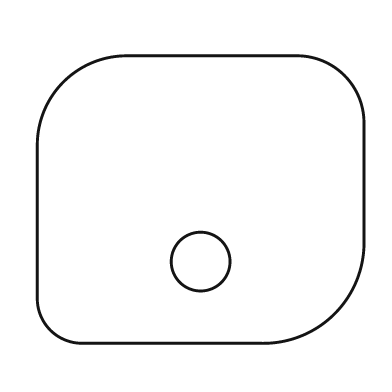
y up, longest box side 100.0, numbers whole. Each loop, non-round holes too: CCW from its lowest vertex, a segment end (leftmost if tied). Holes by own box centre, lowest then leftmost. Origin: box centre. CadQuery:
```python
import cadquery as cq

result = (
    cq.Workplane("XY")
    .moveTo(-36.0, -44.0)
    .lineTo(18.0, -44.0)
    .threePointArc((41.0, -35.0), (50.0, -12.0))
    .lineTo(50.0, 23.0)
    .threePointArc((44.0, 38.0), (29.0, 44.0))
    .lineTo(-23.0, 44.0)
    .threePointArc((-42.0, 36.0), (-50.0, 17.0))
    .lineTo(-50.0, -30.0)
    .threePointArc((-46.0, -40.0), (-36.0, -44.0))
    .close()
    .moveTo(0.0, -19.0)
    .circle(9.0)
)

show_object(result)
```